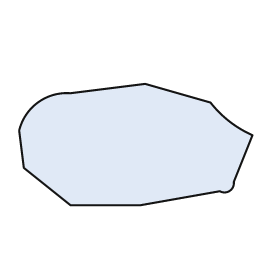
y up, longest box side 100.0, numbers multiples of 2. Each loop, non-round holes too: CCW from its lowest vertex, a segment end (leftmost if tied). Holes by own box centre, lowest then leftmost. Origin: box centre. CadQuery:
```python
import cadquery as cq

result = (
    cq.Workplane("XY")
    .moveTo(-28.0, -26.0)
    .lineTo(2.0, -26.0)
    .lineTo(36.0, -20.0)
    .threePointArc((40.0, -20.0), (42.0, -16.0))
    .lineTo(50.0, 4.0)
    .threePointArc((40.0, 10.0), (32.0, 18.0))
    .lineTo(4.0, 26.0)
    .lineTo(-28.0, 22.0)
    .threePointArc((-42.0, 18.0), (-50.0, 6.0))
    .lineTo(-48.0, -10.0)
    .close()
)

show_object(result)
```